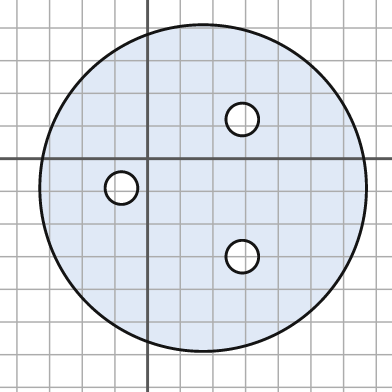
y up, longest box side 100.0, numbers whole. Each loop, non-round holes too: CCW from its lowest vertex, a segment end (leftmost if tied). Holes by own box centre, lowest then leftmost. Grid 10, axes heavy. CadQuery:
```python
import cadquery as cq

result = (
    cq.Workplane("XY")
    .moveTo(17.0, -9.0)
    .circle(50.0)
    .moveTo(29.0, -30.0)
    .circle(5.0)
    .moveTo(-8.0, -9.0)
    .circle(5.0)
    .moveTo(29.0, 12.0)
    .circle(5.0)
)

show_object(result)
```